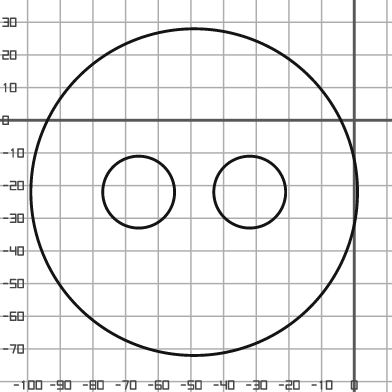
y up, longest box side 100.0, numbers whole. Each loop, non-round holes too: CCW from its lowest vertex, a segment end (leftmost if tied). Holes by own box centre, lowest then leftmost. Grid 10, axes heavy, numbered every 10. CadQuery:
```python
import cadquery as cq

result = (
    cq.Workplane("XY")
    .moveTo(-49.0, -22.0)
    .circle(50.0)
    .moveTo(-66.0, -22.0)
    .circle(11.0)
    .moveTo(-32.0, -22.0)
    .circle(11.0)
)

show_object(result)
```